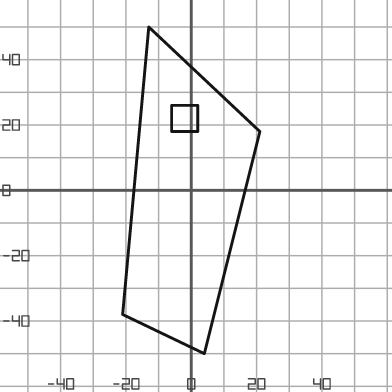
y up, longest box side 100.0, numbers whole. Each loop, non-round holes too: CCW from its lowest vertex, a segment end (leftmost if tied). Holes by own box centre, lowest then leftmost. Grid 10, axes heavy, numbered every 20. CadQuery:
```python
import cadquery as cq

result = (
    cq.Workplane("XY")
    .moveTo(4.0, -50.0)
    .lineTo(21.0, 18.0)
    .lineTo(-13.0, 50.0)
    .lineTo(-21.0, -38.0)
    .close()
    .moveTo(-6.0, 18.0)
    .lineTo(2.0, 18.0)
    .lineTo(2.0, 26.0)
    .lineTo(-6.0, 26.0)
    .close()
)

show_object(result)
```